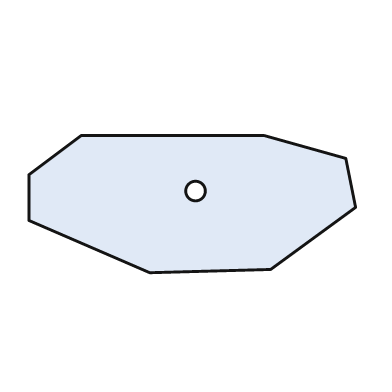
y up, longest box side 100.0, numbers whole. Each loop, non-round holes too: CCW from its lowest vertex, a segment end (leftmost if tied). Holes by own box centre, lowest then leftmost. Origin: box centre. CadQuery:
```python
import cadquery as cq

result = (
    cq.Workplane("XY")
    .moveTo(-13.0, -21.0)
    .lineTo(24.0, -20.0)
    .lineTo(50.0, -1.0)
    .lineTo(47.0, 14.0)
    .lineTo(22.0, 21.0)
    .lineTo(-34.0, 21.0)
    .lineTo(-50.0, 9.0)
    .lineTo(-50.0, -5.0)
    .close()
    .moveTo(1.0, 4.0)
    .circle(3.0)
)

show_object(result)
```